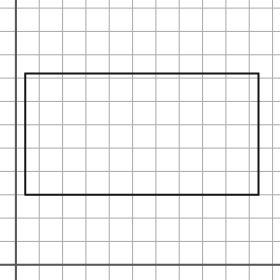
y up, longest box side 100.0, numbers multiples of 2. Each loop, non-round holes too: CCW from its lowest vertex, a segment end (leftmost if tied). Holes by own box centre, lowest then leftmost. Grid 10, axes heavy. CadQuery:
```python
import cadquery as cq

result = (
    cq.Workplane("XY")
    .moveTo(4.0, 30.0)
    .lineTo(104.0, 30.0)
    .lineTo(104.0, 82.0)
    .lineTo(4.0, 82.0)
    .close()
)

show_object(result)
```